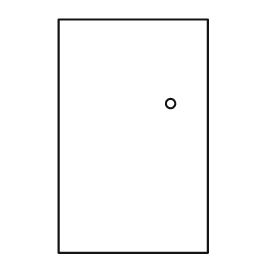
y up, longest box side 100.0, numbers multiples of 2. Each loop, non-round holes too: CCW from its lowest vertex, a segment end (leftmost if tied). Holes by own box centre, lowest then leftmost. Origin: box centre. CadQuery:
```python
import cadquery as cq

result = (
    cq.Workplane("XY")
    .moveTo(-32.0, -50.0)
    .lineTo(32.0, -50.0)
    .lineTo(32.0, 50.0)
    .lineTo(-32.0, 50.0)
    .close()
    .moveTo(16.0, 14.0)
    .circle(2.0)
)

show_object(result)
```